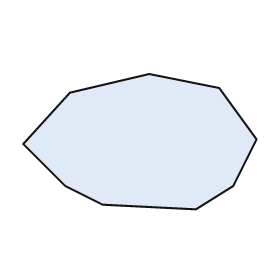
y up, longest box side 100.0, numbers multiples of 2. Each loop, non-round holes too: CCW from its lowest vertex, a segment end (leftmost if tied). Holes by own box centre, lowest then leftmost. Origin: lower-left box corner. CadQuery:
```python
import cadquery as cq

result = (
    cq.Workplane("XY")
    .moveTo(74.0, 0.0)
    .lineTo(90.0, 10.0)
    .lineTo(100.0, 30.0)
    .lineTo(84.0, 52.0)
    .lineTo(54.0, 58.0)
    .lineTo(20.0, 50.0)
    .lineTo(0.0, 28.0)
    .lineTo(18.0, 10.0)
    .lineTo(34.0, 2.0)
    .close()
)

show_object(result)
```